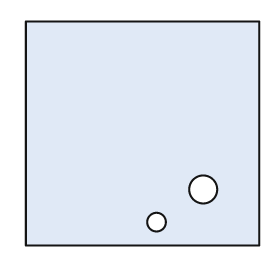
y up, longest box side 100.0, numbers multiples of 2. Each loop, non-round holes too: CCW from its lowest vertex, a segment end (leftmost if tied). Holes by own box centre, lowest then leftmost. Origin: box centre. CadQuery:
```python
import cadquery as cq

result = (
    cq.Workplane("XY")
    .moveTo(-50.0, -48.0)
    .lineTo(50.0, -48.0)
    .lineTo(50.0, 48.0)
    .lineTo(-50.0, 48.0)
    .close()
    .moveTo(6.0, -38.0)
    .circle(4.0)
    .moveTo(26.0, -24.0)
    .circle(6.0)
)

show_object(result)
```